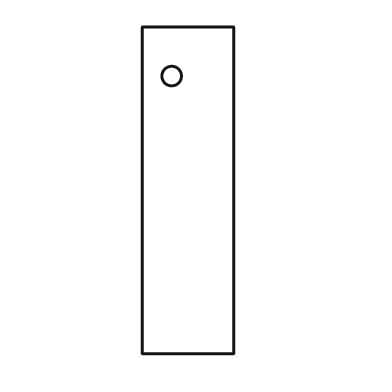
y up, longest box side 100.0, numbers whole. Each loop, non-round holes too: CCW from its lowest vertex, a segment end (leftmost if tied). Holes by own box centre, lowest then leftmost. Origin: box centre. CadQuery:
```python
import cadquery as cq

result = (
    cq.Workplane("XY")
    .moveTo(-14.0, -50.0)
    .lineTo(14.0, -50.0)
    .lineTo(14.0, 50.0)
    .lineTo(-14.0, 50.0)
    .close()
    .moveTo(-5.0, 35.0)
    .circle(3.0)
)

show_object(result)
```